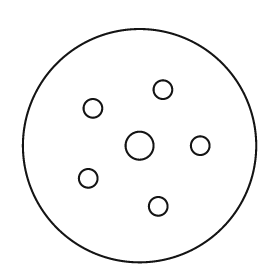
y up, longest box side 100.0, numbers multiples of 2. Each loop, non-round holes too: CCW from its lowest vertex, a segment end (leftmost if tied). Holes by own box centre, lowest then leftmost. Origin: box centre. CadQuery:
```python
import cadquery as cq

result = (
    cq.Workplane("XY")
    .moveTo(0.0, 0.0)
    .circle(50.0)
    .moveTo(8.0, -26.0)
    .circle(4.0)
    .moveTo(-22.0, -14.0)
    .circle(4.0)
    .moveTo(0.0, 0.0)
    .circle(6.0)
    .moveTo(26.0, 0.0)
    .circle(4.0)
    .moveTo(-20.0, 16.0)
    .circle(4.0)
    .moveTo(10.0, 24.0)
    .circle(4.0)
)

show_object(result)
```